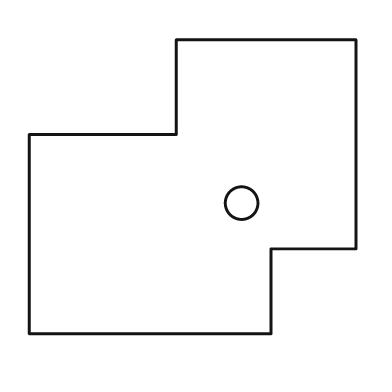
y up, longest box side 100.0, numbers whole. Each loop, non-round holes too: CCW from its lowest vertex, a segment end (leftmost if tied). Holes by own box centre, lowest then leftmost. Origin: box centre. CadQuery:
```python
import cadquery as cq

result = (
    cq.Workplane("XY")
    .moveTo(-50.0, -45.0)
    .lineTo(24.0, -45.0)
    .lineTo(24.0, -19.0)
    .lineTo(50.0, -19.0)
    .lineTo(50.0, 45.0)
    .lineTo(-5.0, 45.0)
    .lineTo(-5.0, 16.0)
    .lineTo(-50.0, 16.0)
    .close()
    .moveTo(15.0, -5.0)
    .circle(5.0)
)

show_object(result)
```